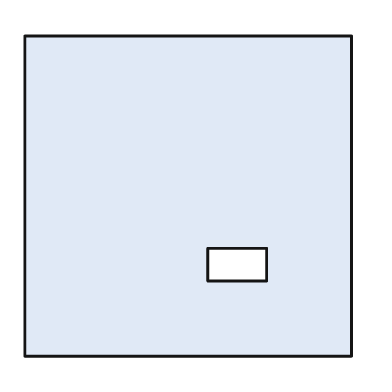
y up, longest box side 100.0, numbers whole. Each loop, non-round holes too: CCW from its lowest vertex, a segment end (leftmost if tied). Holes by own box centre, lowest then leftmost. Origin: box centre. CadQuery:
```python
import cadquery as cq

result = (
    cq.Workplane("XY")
    .moveTo(-50.0, -49.0)
    .lineTo(50.0, -49.0)
    .lineTo(50.0, 49.0)
    .lineTo(-50.0, 49.0)
    .close()
    .moveTo(6.0, -26.0)
    .lineTo(24.0, -26.0)
    .lineTo(24.0, -16.0)
    .lineTo(6.0, -16.0)
    .close()
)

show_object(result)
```